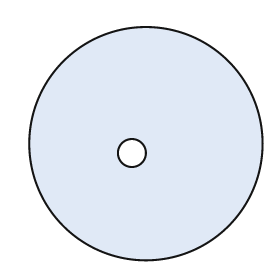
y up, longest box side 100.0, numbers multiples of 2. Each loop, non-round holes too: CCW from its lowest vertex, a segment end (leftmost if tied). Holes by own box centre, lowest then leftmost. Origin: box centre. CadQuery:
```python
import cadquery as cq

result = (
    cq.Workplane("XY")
    .moveTo(0.0, 0.0)
    .circle(50.0)
    .moveTo(-6.0, -4.0)
    .circle(6.0)
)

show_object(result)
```